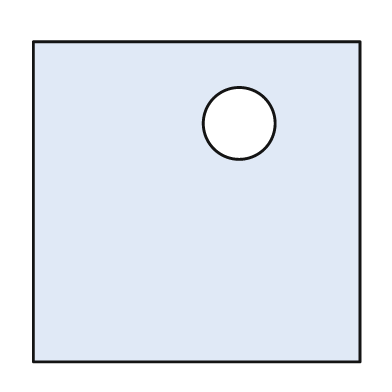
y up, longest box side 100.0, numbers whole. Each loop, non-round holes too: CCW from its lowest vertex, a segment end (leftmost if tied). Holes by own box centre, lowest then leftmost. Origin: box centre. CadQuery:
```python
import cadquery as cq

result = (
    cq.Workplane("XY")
    .moveTo(-50.0, -49.0)
    .lineTo(50.0, -49.0)
    .lineTo(50.0, 49.0)
    .lineTo(-50.0, 49.0)
    .close()
    .moveTo(13.0, 24.0)
    .circle(11.0)
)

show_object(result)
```